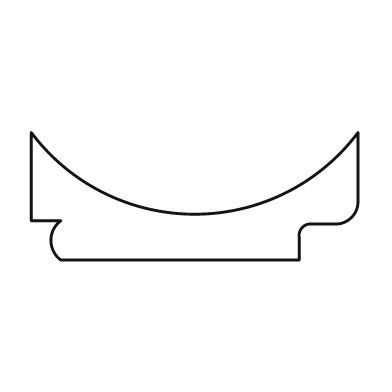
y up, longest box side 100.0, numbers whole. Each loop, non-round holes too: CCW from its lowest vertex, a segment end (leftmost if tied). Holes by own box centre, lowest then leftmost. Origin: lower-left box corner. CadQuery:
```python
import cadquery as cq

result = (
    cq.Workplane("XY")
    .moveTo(9.0, 0.0)
    .lineTo(82.0, 0.0)
    .lineTo(82.0, 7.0)
    .threePointArc((83.0, 10.0), (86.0, 11.0))
    .lineTo(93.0, 11.0)
    .threePointArc((98.0, 13.0), (100.0, 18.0))
    .lineTo(100.0, 39.0)
    .threePointArc((50.0, 14.0), (0.0, 39.0))
    .lineTo(0.0, 12.0)
    .lineTo(9.0, 12.0)
    .threePointArc((6.0, 6.0), (9.0, 0.0))
    .close()
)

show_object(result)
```